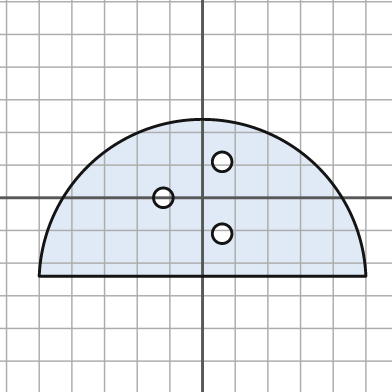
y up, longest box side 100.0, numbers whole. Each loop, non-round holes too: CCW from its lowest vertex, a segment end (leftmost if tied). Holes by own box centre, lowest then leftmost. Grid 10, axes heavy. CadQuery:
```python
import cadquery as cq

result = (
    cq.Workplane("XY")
    .moveTo(-50.0, -24.0)
    .lineTo(50.0, -24.0)
    .threePointArc((0.0, 24.0), (-50.0, -24.0))
    .close()
    .moveTo(6.0, -11.0)
    .circle(3.0)
    .moveTo(-12.0, 0.0)
    .circle(3.0)
    .moveTo(6.0, 11.0)
    .circle(3.0)
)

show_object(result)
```